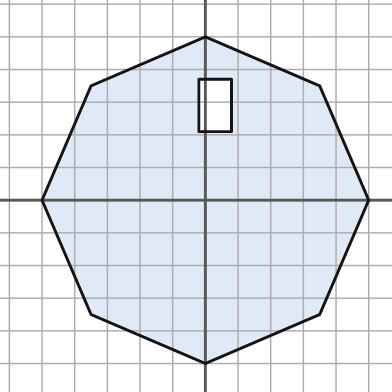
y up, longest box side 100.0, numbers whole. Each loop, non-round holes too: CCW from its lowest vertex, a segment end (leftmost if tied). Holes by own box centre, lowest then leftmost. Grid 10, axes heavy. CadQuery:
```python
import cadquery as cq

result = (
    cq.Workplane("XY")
    .moveTo(0.0, -50.0)
    .lineTo(35.0, -35.0)
    .lineTo(50.0, 0.0)
    .lineTo(35.0, 35.0)
    .lineTo(0.0, 50.0)
    .lineTo(-35.0, 35.0)
    .lineTo(-50.0, 0.0)
    .lineTo(-35.0, -35.0)
    .close()
    .moveTo(-2.0, 21.0)
    .lineTo(8.0, 21.0)
    .lineTo(8.0, 37.0)
    .lineTo(-2.0, 37.0)
    .close()
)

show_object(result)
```